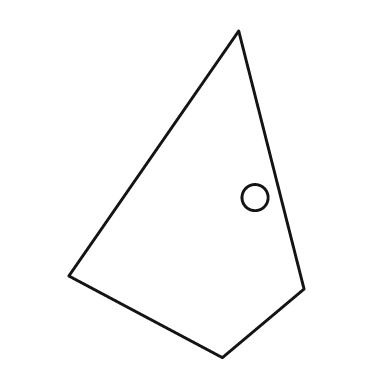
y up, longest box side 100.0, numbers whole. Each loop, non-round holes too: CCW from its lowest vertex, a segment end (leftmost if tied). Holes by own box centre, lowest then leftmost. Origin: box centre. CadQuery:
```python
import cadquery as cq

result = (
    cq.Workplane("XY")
    .moveTo(11.0, -50.0)
    .lineTo(36.0, -29.0)
    .lineTo(16.0, 50.0)
    .lineTo(-36.0, -25.0)
    .close()
    .moveTo(21.0, -1.0)
    .circle(4.0)
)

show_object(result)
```